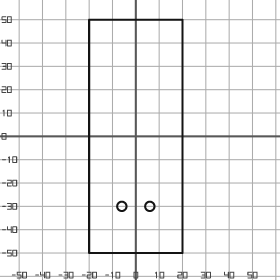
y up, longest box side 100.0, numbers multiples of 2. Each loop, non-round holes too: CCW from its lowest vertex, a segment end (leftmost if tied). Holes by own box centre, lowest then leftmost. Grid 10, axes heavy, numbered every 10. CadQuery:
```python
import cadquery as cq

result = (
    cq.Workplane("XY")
    .moveTo(-20.0, -50.0)
    .lineTo(20.0, -50.0)
    .lineTo(20.0, 50.0)
    .lineTo(-20.0, 50.0)
    .close()
    .moveTo(-6.0, -30.0)
    .circle(2.0)
    .moveTo(6.0, -30.0)
    .circle(2.0)
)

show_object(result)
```